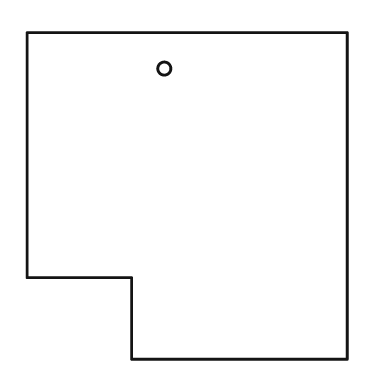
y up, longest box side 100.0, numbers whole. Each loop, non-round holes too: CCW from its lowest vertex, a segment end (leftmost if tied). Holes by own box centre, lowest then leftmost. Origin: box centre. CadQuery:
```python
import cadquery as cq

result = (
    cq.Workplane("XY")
    .moveTo(-17.0, -50.0)
    .lineTo(49.0, -50.0)
    .lineTo(49.0, 50.0)
    .lineTo(-49.0, 50.0)
    .lineTo(-49.0, -25.0)
    .lineTo(-17.0, -25.0)
    .close()
    .moveTo(-7.0, 39.0)
    .circle(2.0)
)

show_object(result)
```